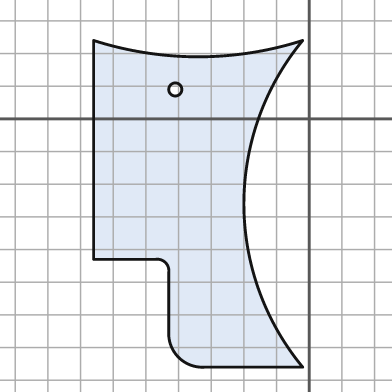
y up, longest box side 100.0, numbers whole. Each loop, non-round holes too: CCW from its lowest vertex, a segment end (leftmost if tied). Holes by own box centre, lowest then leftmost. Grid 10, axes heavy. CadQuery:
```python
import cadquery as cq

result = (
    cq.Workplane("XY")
    .moveTo(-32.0, -76.0)
    .lineTo(-2.0, -76.0)
    .threePointArc((-20.0, -26.0), (-2.0, 24.0))
    .threePointArc((-34.0, 19.0), (-66.0, 24.0))
    .lineTo(-66.0, -43.0)
    .lineTo(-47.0, -43.0)
    .threePointArc((-44.0, -44.0), (-43.0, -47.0))
    .lineTo(-43.0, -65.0)
    .threePointArc((-40.0, -73.0), (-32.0, -76.0))
    .close()
    .moveTo(-41.0, 9.0)
    .circle(2.0)
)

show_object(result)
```